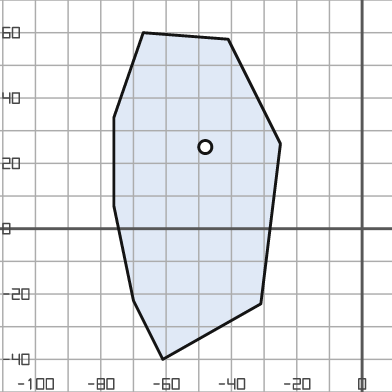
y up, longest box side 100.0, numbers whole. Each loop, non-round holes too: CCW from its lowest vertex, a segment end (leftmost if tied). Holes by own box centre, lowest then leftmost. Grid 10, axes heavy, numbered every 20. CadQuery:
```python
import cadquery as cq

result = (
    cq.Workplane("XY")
    .moveTo(-61.0, -40.0)
    .lineTo(-31.0, -23.0)
    .lineTo(-25.0, 26.0)
    .lineTo(-41.0, 58.0)
    .lineTo(-67.0, 60.0)
    .lineTo(-76.0, 34.0)
    .lineTo(-76.0, 7.0)
    .lineTo(-70.0, -22.0)
    .close()
    .moveTo(-48.0, 25.0)
    .circle(2.0)
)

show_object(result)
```